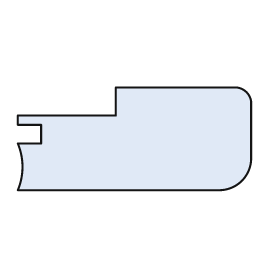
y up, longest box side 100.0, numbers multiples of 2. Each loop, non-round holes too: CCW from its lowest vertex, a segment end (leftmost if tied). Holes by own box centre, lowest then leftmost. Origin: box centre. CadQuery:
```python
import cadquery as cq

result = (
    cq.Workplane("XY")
    .moveTo(-50.0, -22.0)
    .lineTo(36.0, -22.0)
    .threePointArc((46.0, -18.0), (50.0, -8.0))
    .lineTo(50.0, 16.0)
    .threePointArc((48.0, 20.0), (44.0, 22.0))
    .lineTo(-8.0, 22.0)
    .lineTo(-8.0, 10.0)
    .lineTo(-50.0, 10.0)
    .lineTo(-50.0, 6.0)
    .lineTo(-40.0, 6.0)
    .lineTo(-40.0, -2.0)
    .lineTo(-50.0, -2.0)
    .threePointArc((-48.0, -12.0), (-50.0, -22.0))
    .close()
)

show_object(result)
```